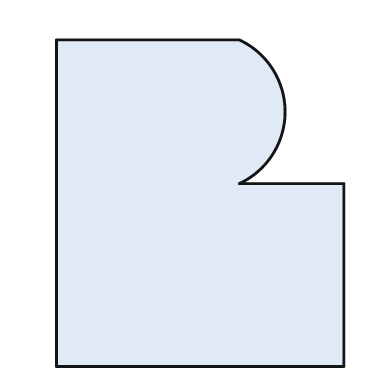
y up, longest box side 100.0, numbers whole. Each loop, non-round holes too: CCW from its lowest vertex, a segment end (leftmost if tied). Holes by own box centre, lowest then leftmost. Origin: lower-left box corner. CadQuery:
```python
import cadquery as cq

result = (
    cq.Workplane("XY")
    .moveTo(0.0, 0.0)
    .lineTo(88.0, 0.0)
    .lineTo(88.0, 56.0)
    .lineTo(56.0, 56.0)
    .threePointArc((70.0, 78.0), (56.0, 100.0))
    .lineTo(0.0, 100.0)
    .close()
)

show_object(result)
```